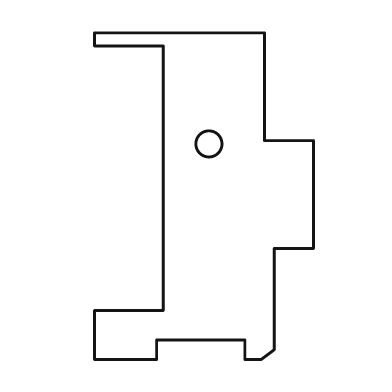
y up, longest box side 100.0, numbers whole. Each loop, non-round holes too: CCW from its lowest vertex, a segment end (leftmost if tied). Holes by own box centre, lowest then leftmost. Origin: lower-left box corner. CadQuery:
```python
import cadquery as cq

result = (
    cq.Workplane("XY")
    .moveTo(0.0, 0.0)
    .lineTo(19.0, 0.0)
    .lineTo(19.0, 6.0)
    .lineTo(46.0, 6.0)
    .lineTo(46.0, 0.0)
    .lineTo(51.0, 0.0)
    .lineTo(55.0, 3.0)
    .lineTo(55.0, 34.0)
    .lineTo(67.0, 34.0)
    .lineTo(67.0, 67.0)
    .lineTo(52.0, 67.0)
    .lineTo(52.0, 100.0)
    .lineTo(0.0, 100.0)
    .lineTo(0.0, 96.0)
    .lineTo(21.0, 96.0)
    .lineTo(21.0, 15.0)
    .lineTo(0.0, 15.0)
    .close()
    .moveTo(35.0, 66.0)
    .circle(4.0)
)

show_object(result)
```